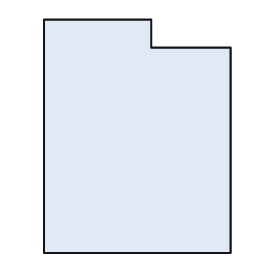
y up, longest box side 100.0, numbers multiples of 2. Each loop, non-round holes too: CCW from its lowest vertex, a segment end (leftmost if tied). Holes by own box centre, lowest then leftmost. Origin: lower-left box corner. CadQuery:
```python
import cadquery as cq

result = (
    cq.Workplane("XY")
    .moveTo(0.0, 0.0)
    .lineTo(80.0, 0.0)
    .lineTo(80.0, 88.0)
    .lineTo(46.0, 88.0)
    .lineTo(46.0, 100.0)
    .lineTo(0.0, 100.0)
    .close()
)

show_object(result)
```